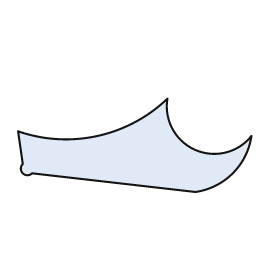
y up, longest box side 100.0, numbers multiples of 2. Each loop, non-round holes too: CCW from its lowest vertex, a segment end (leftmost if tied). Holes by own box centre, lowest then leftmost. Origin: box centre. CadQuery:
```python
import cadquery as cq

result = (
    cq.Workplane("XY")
    .moveTo(26.0, -20.0)
    .threePointArc((42.0, -12.0), (50.0, 4.0))
    .threePointArc((26.0, -2.0), (14.0, 20.0))
    .threePointArc((-16.0, 4.0), (-50.0, 6.0))
    .lineTo(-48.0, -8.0)
    .threePointArc((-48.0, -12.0), (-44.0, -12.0))
    .close()
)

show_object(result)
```